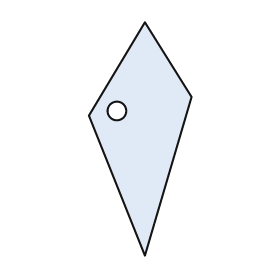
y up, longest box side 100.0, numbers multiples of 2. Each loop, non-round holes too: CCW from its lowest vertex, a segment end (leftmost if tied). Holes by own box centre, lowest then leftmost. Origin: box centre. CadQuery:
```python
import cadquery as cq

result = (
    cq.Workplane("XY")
    .moveTo(2.0, -50.0)
    .lineTo(22.0, 18.0)
    .lineTo(2.0, 50.0)
    .lineTo(-22.0, 10.0)
    .close()
    .moveTo(-10.0, 12.0)
    .circle(4.0)
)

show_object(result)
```